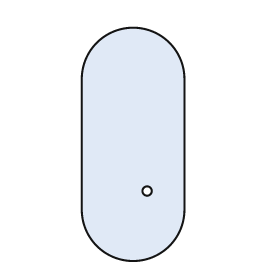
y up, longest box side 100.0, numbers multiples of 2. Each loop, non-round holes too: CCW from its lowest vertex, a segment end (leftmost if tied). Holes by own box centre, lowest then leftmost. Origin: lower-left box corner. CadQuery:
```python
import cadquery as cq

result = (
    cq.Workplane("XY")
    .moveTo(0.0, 22.0)
    .threePointArc((22.0, 0.0), (44.0, 22.0))
    .lineTo(44.0, 78.0)
    .threePointArc((22.0, 100.0), (0.0, 78.0))
    .close()
    .moveTo(28.0, 30.0)
    .circle(2.0)
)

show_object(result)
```